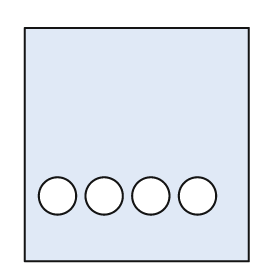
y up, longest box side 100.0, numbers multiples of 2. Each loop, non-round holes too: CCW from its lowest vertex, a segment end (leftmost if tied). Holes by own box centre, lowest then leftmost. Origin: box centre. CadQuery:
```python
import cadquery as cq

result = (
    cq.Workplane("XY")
    .moveTo(-48.0, -50.0)
    .lineTo(48.0, -50.0)
    .lineTo(48.0, 50.0)
    .lineTo(-48.0, 50.0)
    .close()
    .moveTo(-34.0, -22.0)
    .circle(8.0)
    .moveTo(-14.0, -22.0)
    .circle(8.0)
    .moveTo(6.0, -22.0)
    .circle(8.0)
    .moveTo(26.0, -22.0)
    .circle(8.0)
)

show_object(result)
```